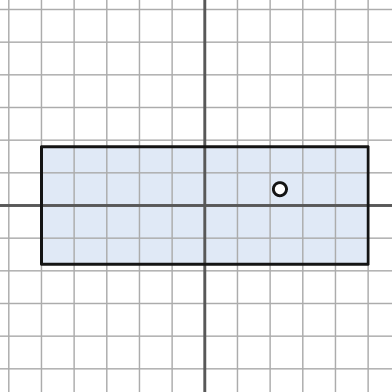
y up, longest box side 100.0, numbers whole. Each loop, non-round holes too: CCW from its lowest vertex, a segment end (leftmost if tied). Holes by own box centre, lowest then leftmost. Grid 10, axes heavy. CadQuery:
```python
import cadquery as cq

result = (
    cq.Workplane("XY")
    .moveTo(-50.0, -18.0)
    .lineTo(50.0, -18.0)
    .lineTo(50.0, 18.0)
    .lineTo(-50.0, 18.0)
    .close()
    .moveTo(23.0, 5.0)
    .circle(2.0)
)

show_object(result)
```